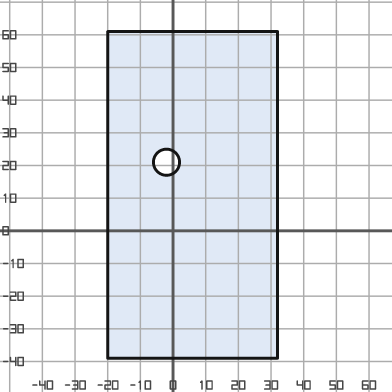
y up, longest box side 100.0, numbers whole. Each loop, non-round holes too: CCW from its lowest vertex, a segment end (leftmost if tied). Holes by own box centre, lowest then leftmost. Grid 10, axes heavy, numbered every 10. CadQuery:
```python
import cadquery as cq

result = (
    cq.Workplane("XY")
    .moveTo(-20.0, -39.0)
    .lineTo(32.0, -39.0)
    .lineTo(32.0, 61.0)
    .lineTo(-20.0, 61.0)
    .close()
    .moveTo(-2.0, 21.0)
    .circle(4.0)
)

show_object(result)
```